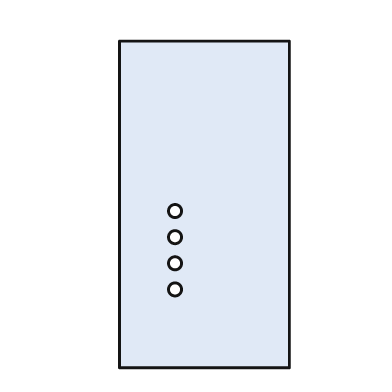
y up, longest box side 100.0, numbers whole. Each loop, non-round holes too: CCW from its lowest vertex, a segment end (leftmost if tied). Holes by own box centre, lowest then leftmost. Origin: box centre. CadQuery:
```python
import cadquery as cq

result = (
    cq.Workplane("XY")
    .moveTo(-26.0, -50.0)
    .lineTo(26.0, -50.0)
    .lineTo(26.0, 50.0)
    .lineTo(-26.0, 50.0)
    .close()
    .moveTo(-9.0, -26.0)
    .circle(2.0)
    .moveTo(-9.0, -18.0)
    .circle(2.0)
    .moveTo(-9.0, -10.0)
    .circle(2.0)
    .moveTo(-9.0, -2.0)
    .circle(2.0)
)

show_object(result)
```